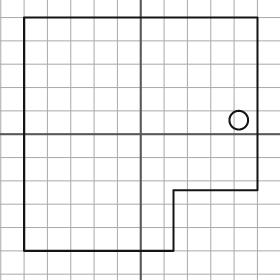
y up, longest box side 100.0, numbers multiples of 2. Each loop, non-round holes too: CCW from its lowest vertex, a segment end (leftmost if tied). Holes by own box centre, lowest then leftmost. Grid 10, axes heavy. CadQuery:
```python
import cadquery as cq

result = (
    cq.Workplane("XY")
    .moveTo(-50.0, -50.0)
    .lineTo(14.0, -50.0)
    .lineTo(14.0, -24.0)
    .lineTo(50.0, -24.0)
    .lineTo(50.0, 50.0)
    .lineTo(-50.0, 50.0)
    .close()
    .moveTo(42.0, 6.0)
    .circle(4.0)
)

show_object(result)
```